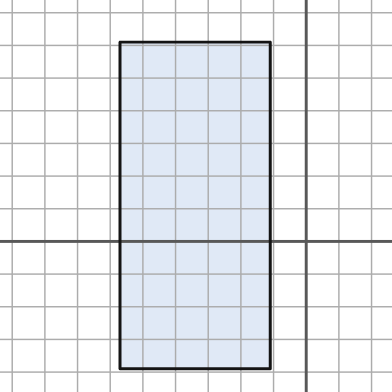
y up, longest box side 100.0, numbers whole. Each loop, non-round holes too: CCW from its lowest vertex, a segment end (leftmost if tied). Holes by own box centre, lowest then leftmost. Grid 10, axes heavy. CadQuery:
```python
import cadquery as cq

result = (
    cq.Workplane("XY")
    .moveTo(-57.0, -39.0)
    .lineTo(-11.0, -39.0)
    .lineTo(-11.0, 61.0)
    .lineTo(-57.0, 61.0)
    .close()
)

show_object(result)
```